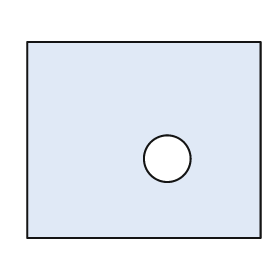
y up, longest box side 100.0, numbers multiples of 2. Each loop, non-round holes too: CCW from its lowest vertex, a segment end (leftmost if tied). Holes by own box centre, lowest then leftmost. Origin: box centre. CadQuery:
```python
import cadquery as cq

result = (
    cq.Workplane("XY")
    .moveTo(-50.0, -42.0)
    .lineTo(50.0, -42.0)
    .lineTo(50.0, 42.0)
    .lineTo(-50.0, 42.0)
    .close()
    .moveTo(10.0, -8.0)
    .circle(10.0)
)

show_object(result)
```